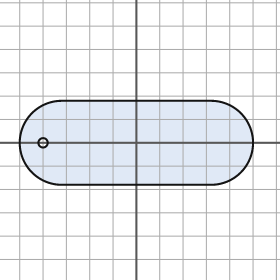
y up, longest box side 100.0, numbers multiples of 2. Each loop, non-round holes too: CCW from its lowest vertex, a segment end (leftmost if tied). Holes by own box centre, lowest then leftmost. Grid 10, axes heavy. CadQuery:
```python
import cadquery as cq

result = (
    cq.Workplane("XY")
    .moveTo(-32.0, -18.0)
    .lineTo(32.0, -18.0)
    .threePointArc((50.0, 0.0), (32.0, 18.0))
    .lineTo(-32.0, 18.0)
    .threePointArc((-50.0, 0.0), (-32.0, -18.0))
    .close()
    .moveTo(-40.0, 0.0)
    .circle(2.0)
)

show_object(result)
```